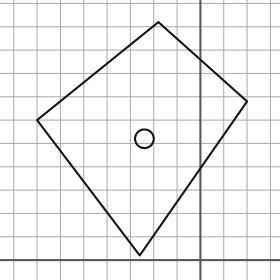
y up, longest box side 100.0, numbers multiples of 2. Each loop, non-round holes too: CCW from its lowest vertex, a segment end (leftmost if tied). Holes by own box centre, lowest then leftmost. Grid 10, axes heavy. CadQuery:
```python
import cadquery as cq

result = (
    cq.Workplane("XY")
    .moveTo(-26.0, 2.0)
    .lineTo(20.0, 68.0)
    .lineTo(-18.0, 102.0)
    .lineTo(-70.0, 60.0)
    .close()
    .moveTo(-24.0, 52.0)
    .circle(4.0)
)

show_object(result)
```